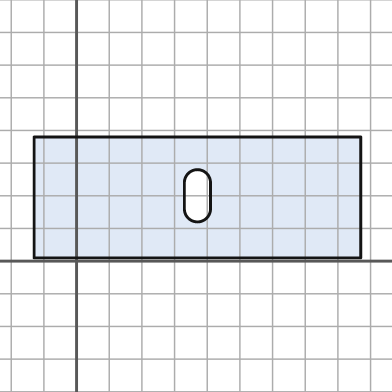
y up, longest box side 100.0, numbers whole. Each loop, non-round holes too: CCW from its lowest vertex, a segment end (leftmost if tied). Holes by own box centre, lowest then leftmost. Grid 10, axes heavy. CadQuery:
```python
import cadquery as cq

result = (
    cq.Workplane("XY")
    .moveTo(-13.0, 1.0)
    .lineTo(87.0, 1.0)
    .lineTo(87.0, 38.0)
    .lineTo(-13.0, 38.0)
    .close()
    .moveTo(33.0, 16.0)
    .threePointArc((37.0, 12.0), (41.0, 16.0))
    .lineTo(41.0, 24.0)
    .threePointArc((37.0, 28.0), (33.0, 24.0))
    .close()
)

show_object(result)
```